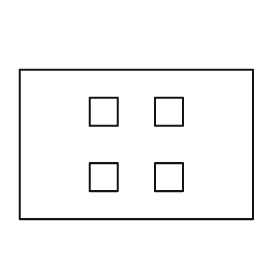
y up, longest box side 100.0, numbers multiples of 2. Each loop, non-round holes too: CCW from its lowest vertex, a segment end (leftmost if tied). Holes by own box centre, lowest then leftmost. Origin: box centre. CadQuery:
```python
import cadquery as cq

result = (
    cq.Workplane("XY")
    .moveTo(-50.0, -32.0)
    .lineTo(50.0, -32.0)
    .lineTo(50.0, 32.0)
    .lineTo(-50.0, 32.0)
    .close()
    .moveTo(-20.0, -20.0)
    .lineTo(-8.0, -20.0)
    .lineTo(-8.0, -8.0)
    .lineTo(-20.0, -8.0)
    .close()
    .moveTo(8.0, -20.0)
    .lineTo(20.0, -20.0)
    .lineTo(20.0, -8.0)
    .lineTo(8.0, -8.0)
    .close()
    .moveTo(-20.0, 8.0)
    .lineTo(-8.0, 8.0)
    .lineTo(-8.0, 20.0)
    .lineTo(-20.0, 20.0)
    .close()
    .moveTo(8.0, 8.0)
    .lineTo(20.0, 8.0)
    .lineTo(20.0, 20.0)
    .lineTo(8.0, 20.0)
    .close()
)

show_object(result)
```